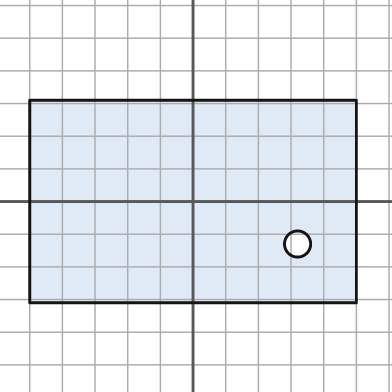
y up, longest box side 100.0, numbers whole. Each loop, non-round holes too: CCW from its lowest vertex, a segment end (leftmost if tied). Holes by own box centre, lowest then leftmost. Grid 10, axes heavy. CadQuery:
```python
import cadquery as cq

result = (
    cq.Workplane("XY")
    .moveTo(-50.0, -31.0)
    .lineTo(50.0, -31.0)
    .lineTo(50.0, 31.0)
    .lineTo(-50.0, 31.0)
    .close()
    .moveTo(32.0, -13.0)
    .circle(4.0)
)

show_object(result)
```